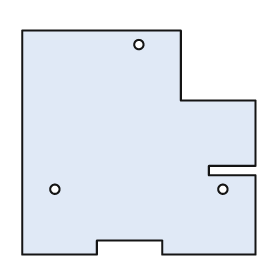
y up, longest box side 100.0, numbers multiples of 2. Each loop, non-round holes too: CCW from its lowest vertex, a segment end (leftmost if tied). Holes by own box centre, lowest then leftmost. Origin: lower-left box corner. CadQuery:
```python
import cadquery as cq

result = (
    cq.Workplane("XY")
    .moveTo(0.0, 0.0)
    .lineTo(32.0, 0.0)
    .lineTo(32.0, 6.0)
    .lineTo(60.0, 6.0)
    .lineTo(60.0, 0.0)
    .lineTo(100.0, 0.0)
    .lineTo(100.0, 34.0)
    .lineTo(80.0, 34.0)
    .lineTo(80.0, 38.0)
    .lineTo(100.0, 38.0)
    .lineTo(100.0, 66.0)
    .lineTo(68.0, 66.0)
    .lineTo(68.0, 96.0)
    .lineTo(0.0, 96.0)
    .close()
    .moveTo(14.0, 28.0)
    .circle(2.0)
    .moveTo(86.0, 28.0)
    .circle(2.0)
    .moveTo(50.0, 90.0)
    .circle(2.0)
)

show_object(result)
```